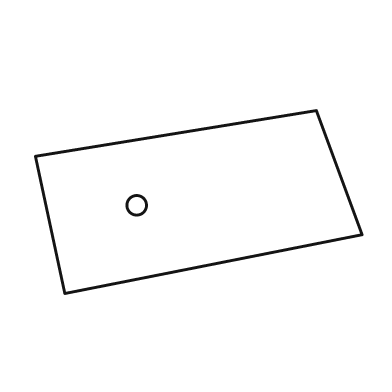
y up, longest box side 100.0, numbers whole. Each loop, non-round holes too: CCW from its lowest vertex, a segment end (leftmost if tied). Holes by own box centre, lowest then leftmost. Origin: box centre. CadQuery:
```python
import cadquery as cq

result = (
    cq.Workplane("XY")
    .moveTo(-41.0, -28.0)
    .lineTo(50.0, -10.0)
    .lineTo(36.0, 28.0)
    .lineTo(-50.0, 14.0)
    .close()
    .moveTo(-19.0, -1.0)
    .circle(3.0)
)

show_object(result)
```